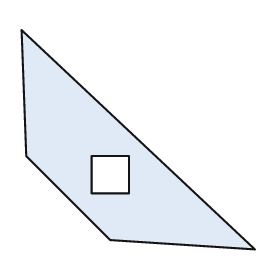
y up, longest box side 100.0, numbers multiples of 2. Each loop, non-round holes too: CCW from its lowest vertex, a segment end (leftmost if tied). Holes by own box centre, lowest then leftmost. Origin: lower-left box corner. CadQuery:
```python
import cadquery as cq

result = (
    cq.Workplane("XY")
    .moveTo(100.0, 0.0)
    .lineTo(0.0, 94.0)
    .lineTo(2.0, 40.0)
    .lineTo(38.0, 4.0)
    .close()
    .moveTo(30.0, 24.0)
    .lineTo(46.0, 24.0)
    .lineTo(46.0, 40.0)
    .lineTo(30.0, 40.0)
    .close()
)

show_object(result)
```